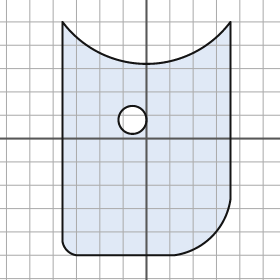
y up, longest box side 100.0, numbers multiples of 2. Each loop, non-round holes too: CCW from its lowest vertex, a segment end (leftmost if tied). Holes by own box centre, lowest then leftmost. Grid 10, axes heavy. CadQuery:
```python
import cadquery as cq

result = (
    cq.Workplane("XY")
    .moveTo(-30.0, -50.0)
    .lineTo(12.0, -50.0)
    .threePointArc((28.0, -42.0), (36.0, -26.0))
    .lineTo(36.0, 50.0)
    .threePointArc((0.0, 32.0), (-36.0, 50.0))
    .lineTo(-36.0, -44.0)
    .threePointArc((-34.0, -48.0), (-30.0, -50.0))
    .close()
    .moveTo(-6.0, 8.0)
    .circle(6.0)
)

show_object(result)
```